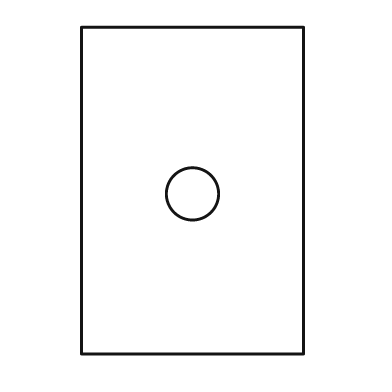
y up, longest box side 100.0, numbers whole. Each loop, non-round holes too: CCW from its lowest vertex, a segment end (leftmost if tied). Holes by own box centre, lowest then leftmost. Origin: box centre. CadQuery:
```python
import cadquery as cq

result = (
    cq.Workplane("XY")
    .moveTo(-34.0, -50.0)
    .lineTo(34.0, -50.0)
    .lineTo(34.0, 50.0)
    .lineTo(-34.0, 50.0)
    .close()
    .moveTo(0.0, -1.0)
    .circle(8.0)
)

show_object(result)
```